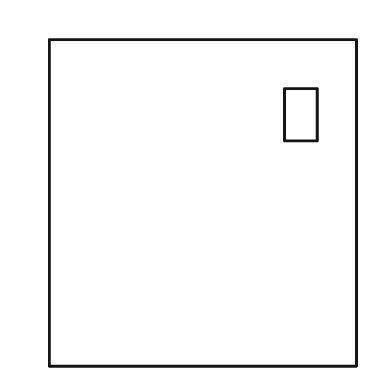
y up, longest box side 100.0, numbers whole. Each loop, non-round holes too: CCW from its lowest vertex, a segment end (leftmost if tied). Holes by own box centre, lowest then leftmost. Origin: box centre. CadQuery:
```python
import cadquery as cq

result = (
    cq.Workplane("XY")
    .moveTo(-47.0, -50.0)
    .lineTo(47.0, -50.0)
    .lineTo(47.0, 50.0)
    .lineTo(-47.0, 50.0)
    .close()
    .moveTo(25.0, 19.0)
    .lineTo(35.0, 19.0)
    .lineTo(35.0, 35.0)
    .lineTo(25.0, 35.0)
    .close()
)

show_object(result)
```